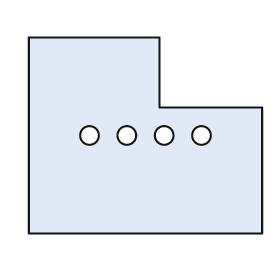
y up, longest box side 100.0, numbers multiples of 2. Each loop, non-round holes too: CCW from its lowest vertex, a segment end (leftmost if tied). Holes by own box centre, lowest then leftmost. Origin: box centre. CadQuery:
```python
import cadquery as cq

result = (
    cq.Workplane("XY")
    .moveTo(-50.0, -42.0)
    .lineTo(50.0, -42.0)
    .lineTo(50.0, 12.0)
    .lineTo(6.0, 12.0)
    .lineTo(6.0, 42.0)
    .lineTo(-50.0, 42.0)
    .close()
    .moveTo(-24.0, 0.0)
    .circle(4.0)
    .moveTo(-8.0, 0.0)
    .circle(4.0)
    .moveTo(8.0, 0.0)
    .circle(4.0)
    .moveTo(24.0, 0.0)
    .circle(4.0)
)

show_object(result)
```